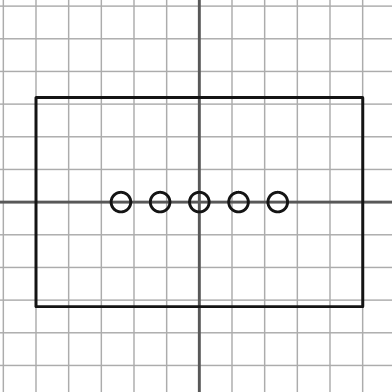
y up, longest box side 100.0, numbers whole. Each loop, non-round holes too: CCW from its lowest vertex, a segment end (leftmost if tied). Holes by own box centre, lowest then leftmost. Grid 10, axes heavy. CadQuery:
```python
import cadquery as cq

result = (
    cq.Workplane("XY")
    .moveTo(-50.0, -32.0)
    .lineTo(50.0, -32.0)
    .lineTo(50.0, 32.0)
    .lineTo(-50.0, 32.0)
    .close()
    .moveTo(-24.0, 0.0)
    .circle(3.0)
    .moveTo(-12.0, 0.0)
    .circle(3.0)
    .moveTo(0.0, 0.0)
    .circle(3.0)
    .moveTo(12.0, 0.0)
    .circle(3.0)
    .moveTo(24.0, 0.0)
    .circle(3.0)
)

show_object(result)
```